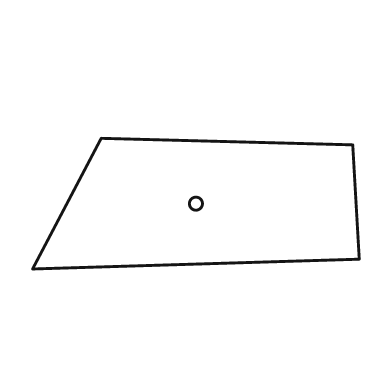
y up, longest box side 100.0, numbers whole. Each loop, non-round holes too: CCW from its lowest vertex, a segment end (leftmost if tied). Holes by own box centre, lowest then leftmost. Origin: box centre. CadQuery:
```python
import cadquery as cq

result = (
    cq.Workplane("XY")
    .moveTo(-50.0, -20.0)
    .lineTo(50.0, -17.0)
    .lineTo(48.0, 18.0)
    .lineTo(-29.0, 20.0)
    .close()
    .moveTo(0.0, 0.0)
    .circle(2.0)
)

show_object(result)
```